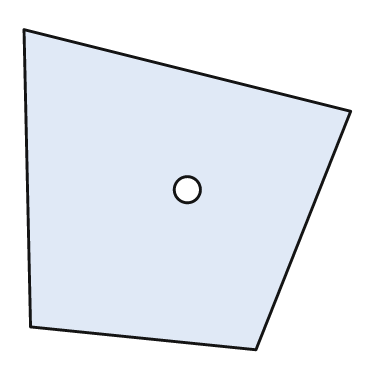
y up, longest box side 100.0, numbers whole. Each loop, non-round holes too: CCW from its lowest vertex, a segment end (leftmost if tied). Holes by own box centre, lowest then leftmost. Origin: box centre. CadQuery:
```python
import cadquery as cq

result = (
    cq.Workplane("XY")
    .moveTo(21.0, -49.0)
    .lineTo(50.0, 24.0)
    .lineTo(-50.0, 49.0)
    .lineTo(-48.0, -42.0)
    .close()
    .moveTo(0.0, 0.0)
    .circle(4.0)
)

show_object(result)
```